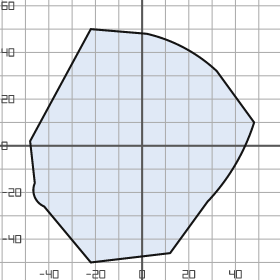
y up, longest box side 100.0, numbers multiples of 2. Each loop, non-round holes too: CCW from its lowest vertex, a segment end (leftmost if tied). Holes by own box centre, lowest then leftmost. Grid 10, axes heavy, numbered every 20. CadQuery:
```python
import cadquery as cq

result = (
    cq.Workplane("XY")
    .moveTo(-22.0, -50.0)
    .lineTo(12.0, -46.0)
    .lineTo(28.0, -24.0)
    .threePointArc((40.0, -8.0), (48.0, 10.0))
    .lineTo(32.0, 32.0)
    .threePointArc((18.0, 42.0), (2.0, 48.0))
    .lineTo(-22.0, 50.0)
    .lineTo(-48.0, 2.0)
    .lineTo(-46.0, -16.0)
    .threePointArc((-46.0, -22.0), (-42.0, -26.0))
    .close()
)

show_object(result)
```